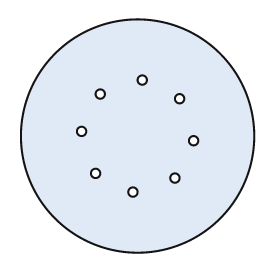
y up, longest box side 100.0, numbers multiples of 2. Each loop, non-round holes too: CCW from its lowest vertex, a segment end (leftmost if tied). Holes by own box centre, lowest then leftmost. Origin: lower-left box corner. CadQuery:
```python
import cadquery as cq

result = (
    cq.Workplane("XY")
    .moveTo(50.0, 50.0)
    .circle(50.0)
    .moveTo(48.0, 26.0)
    .circle(2.0)
    .moveTo(66.0, 32.0)
    .circle(2.0)
    .moveTo(32.0, 34.0)
    .circle(2.0)
    .moveTo(74.0, 48.0)
    .circle(2.0)
    .moveTo(26.0, 52.0)
    .circle(2.0)
    .moveTo(68.0, 66.0)
    .circle(2.0)
    .moveTo(34.0, 68.0)
    .circle(2.0)
    .moveTo(52.0, 74.0)
    .circle(2.0)
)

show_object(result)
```